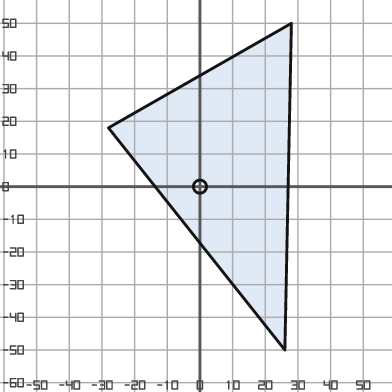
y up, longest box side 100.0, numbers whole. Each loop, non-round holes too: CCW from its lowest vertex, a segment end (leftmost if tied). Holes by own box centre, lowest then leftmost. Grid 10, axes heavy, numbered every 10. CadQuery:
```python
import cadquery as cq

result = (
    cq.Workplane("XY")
    .moveTo(26.0, -50.0)
    .lineTo(28.0, 50.0)
    .lineTo(-28.0, 18.0)
    .close()
    .moveTo(0.0, 0.0)
    .circle(2.0)
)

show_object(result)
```